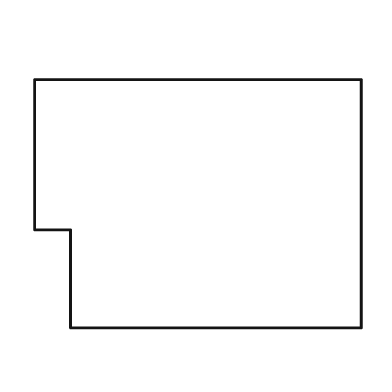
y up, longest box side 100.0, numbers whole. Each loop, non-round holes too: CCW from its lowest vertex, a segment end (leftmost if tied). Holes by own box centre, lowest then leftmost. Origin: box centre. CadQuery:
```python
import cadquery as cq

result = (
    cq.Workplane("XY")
    .moveTo(-39.0, -38.0)
    .lineTo(50.0, -38.0)
    .lineTo(50.0, 38.0)
    .lineTo(-50.0, 38.0)
    .lineTo(-50.0, -8.0)
    .lineTo(-39.0, -8.0)
    .close()
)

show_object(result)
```